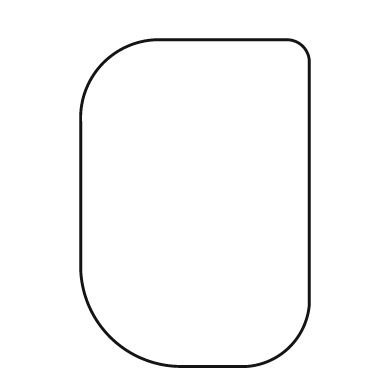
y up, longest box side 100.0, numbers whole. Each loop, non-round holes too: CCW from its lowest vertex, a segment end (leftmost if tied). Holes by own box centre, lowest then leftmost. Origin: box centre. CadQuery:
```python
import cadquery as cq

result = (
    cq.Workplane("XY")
    .moveTo(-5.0, -50.0)
    .lineTo(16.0, -50.0)
    .threePointArc((29.0, -44.0), (35.0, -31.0))
    .lineTo(35.0, 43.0)
    .threePointArc((33.0, 48.0), (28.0, 50.0))
    .lineTo(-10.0, 50.0)
    .threePointArc((-28.0, 43.0), (-35.0, 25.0))
    .lineTo(-35.0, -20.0)
    .threePointArc((-26.0, -41.0), (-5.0, -50.0))
    .close()
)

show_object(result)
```